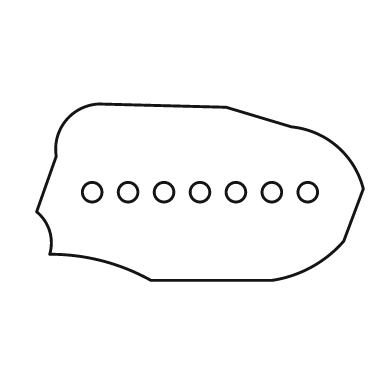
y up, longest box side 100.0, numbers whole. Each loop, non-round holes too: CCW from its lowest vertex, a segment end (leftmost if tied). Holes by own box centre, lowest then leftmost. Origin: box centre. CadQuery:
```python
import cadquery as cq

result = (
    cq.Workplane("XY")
    .moveTo(-15.0, -27.0)
    .lineTo(22.0, -27.0)
    .threePointArc((34.0, -23.0), (44.0, -15.0))
    .lineTo(50.0, 1.0)
    .threePointArc((42.0, 14.0), (28.0, 20.0))
    .lineTo(8.0, 26.0)
    .lineTo(-31.0, 27.0)
    .threePointArc((-41.0, 22.0), (-44.0, 11.0))
    .lineTo(-50.0, -6.0)
    .threePointArc((-46.0, -12.0), (-46.0, -19.0))
    .threePointArc((-30.0, -21.0), (-15.0, -27.0))
    .close()
    .moveTo(-33.0, 0.0)
    .circle(3.0)
    .moveTo(-22.0, 0.0)
    .circle(3.0)
    .moveTo(-11.0, 0.0)
    .circle(3.0)
    .moveTo(0.0, 0.0)
    .circle(3.0)
    .moveTo(11.0, 0.0)
    .circle(3.0)
    .moveTo(22.0, 0.0)
    .circle(3.0)
    .moveTo(33.0, 0.0)
    .circle(3.0)
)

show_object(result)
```